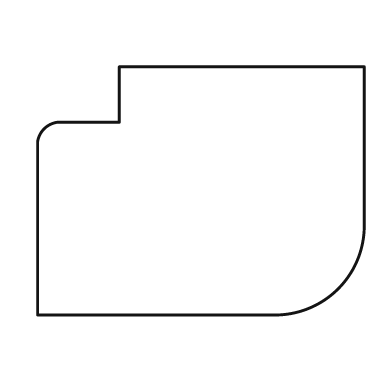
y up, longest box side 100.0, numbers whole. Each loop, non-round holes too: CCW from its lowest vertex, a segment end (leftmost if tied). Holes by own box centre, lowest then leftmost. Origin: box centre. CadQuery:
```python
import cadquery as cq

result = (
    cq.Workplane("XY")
    .moveTo(-50.0, -38.0)
    .lineTo(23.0, -38.0)
    .threePointArc((42.0, -30.0), (50.0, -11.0))
    .lineTo(50.0, 38.0)
    .lineTo(-25.0, 38.0)
    .lineTo(-25.0, 21.0)
    .lineTo(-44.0, 21.0)
    .threePointArc((-48.0, 19.0), (-50.0, 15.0))
    .close()
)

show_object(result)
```